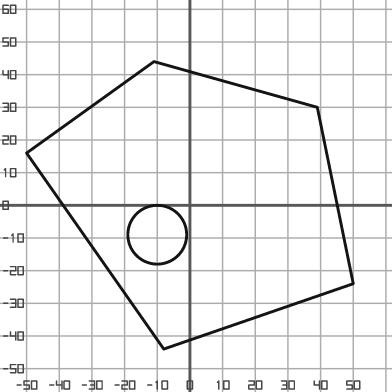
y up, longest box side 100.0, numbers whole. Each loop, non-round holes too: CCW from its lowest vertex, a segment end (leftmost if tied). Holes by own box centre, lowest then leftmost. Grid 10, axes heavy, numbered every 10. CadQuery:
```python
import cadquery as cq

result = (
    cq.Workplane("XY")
    .moveTo(-8.0, -44.0)
    .lineTo(50.0, -24.0)
    .lineTo(39.0, 30.0)
    .lineTo(-11.0, 44.0)
    .lineTo(-50.0, 16.0)
    .close()
    .moveTo(-10.0, -9.0)
    .circle(9.0)
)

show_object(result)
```